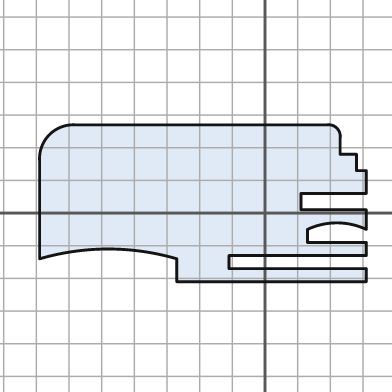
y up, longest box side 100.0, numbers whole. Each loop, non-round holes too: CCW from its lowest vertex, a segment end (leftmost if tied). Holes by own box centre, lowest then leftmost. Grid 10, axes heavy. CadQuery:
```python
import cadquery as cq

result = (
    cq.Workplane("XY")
    .moveTo(-27.0, -21.0)
    .lineTo(31.0, -21.0)
    .lineTo(31.0, -17.0)
    .lineTo(-11.0, -17.0)
    .lineTo(-11.0, -13.0)
    .lineTo(31.0, -13.0)
    .lineTo(31.0, -9.0)
    .lineTo(13.0, -9.0)
    .lineTo(13.0, -5.0)
    .threePointArc((22.0, -3.0), (31.0, -5.0))
    .lineTo(31.0, 1.0)
    .lineTo(11.0, 1.0)
    .lineTo(11.0, 6.0)
    .lineTo(31.0, 6.0)
    .lineTo(31.0, 13.0)
    .lineTo(28.0, 13.0)
    .lineTo(28.0, 18.0)
    .lineTo(23.0, 18.0)
    .lineTo(23.0, 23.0)
    .threePointArc((22.0, 26.0), (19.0, 27.0))
    .lineTo(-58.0, 27.0)
    .threePointArc((-66.0, 24.0), (-69.0, 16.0))
    .lineTo(-69.0, -14.0)
    .threePointArc((-48.0, -11.0), (-27.0, -14.0))
    .close()
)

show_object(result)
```